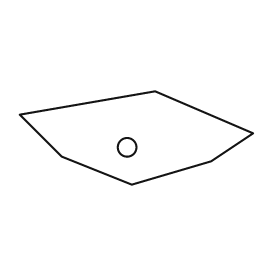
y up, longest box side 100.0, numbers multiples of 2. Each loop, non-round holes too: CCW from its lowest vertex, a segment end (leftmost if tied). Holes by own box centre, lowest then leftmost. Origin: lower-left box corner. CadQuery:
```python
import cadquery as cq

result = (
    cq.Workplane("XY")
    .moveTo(48.0, 0.0)
    .lineTo(82.0, 10.0)
    .lineTo(100.0, 22.0)
    .lineTo(58.0, 40.0)
    .lineTo(0.0, 30.0)
    .lineTo(18.0, 12.0)
    .close()
    .moveTo(46.0, 16.0)
    .circle(4.0)
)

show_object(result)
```